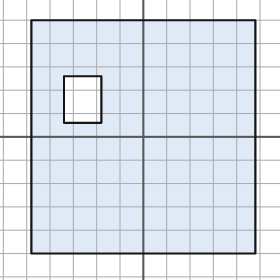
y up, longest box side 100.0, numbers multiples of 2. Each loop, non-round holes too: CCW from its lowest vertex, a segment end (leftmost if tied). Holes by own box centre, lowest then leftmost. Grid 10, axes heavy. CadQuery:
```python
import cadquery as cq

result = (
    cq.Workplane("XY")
    .moveTo(-48.0, -50.0)
    .lineTo(48.0, -50.0)
    .lineTo(48.0, 50.0)
    .lineTo(-48.0, 50.0)
    .close()
    .moveTo(-34.0, 6.0)
    .lineTo(-18.0, 6.0)
    .lineTo(-18.0, 26.0)
    .lineTo(-34.0, 26.0)
    .close()
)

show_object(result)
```